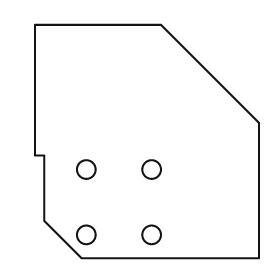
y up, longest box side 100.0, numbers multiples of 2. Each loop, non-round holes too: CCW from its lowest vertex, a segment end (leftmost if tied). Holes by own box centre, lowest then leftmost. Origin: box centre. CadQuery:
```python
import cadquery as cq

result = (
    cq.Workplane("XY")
    .moveTo(-28.0, -50.0)
    .lineTo(48.0, -50.0)
    .lineTo(48.0, 8.0)
    .lineTo(6.0, 50.0)
    .lineTo(-48.0, 50.0)
    .lineTo(-48.0, -6.0)
    .lineTo(-44.0, -6.0)
    .lineTo(-44.0, -34.0)
    .close()
    .moveTo(-26.0, -40.0)
    .circle(4.0)
    .moveTo(2.0, -40.0)
    .circle(4.0)
    .moveTo(-26.0, -12.0)
    .circle(4.0)
    .moveTo(2.0, -12.0)
    .circle(4.0)
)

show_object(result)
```